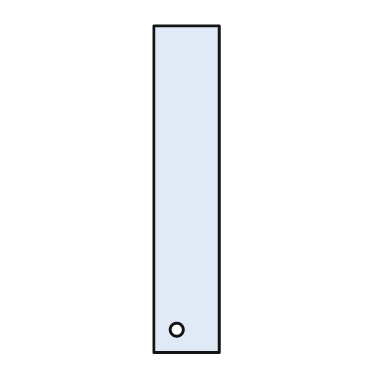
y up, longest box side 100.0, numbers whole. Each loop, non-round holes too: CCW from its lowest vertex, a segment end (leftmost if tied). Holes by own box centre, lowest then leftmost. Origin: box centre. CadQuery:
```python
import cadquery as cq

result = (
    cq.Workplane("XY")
    .moveTo(-10.0, -50.0)
    .lineTo(10.0, -50.0)
    .lineTo(10.0, 50.0)
    .lineTo(-10.0, 50.0)
    .close()
    .moveTo(-3.0, -43.0)
    .circle(2.0)
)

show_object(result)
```